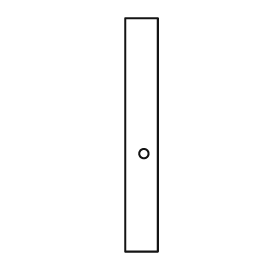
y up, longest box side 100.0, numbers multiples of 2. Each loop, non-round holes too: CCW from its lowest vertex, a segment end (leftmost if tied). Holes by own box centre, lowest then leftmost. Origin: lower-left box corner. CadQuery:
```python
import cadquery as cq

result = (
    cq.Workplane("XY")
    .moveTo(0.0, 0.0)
    .lineTo(14.0, 0.0)
    .lineTo(14.0, 100.0)
    .lineTo(0.0, 100.0)
    .close()
    .moveTo(8.0, 42.0)
    .circle(2.0)
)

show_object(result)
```